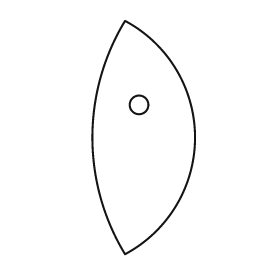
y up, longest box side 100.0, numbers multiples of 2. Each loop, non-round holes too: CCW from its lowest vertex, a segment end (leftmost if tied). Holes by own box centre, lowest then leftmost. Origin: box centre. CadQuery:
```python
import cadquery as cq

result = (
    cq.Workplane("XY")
    .moveTo(-8.0, -50.0)
    .threePointArc((22.0, 0.0), (-8.0, 50.0))
    .threePointArc((-22.0, 0.0), (-8.0, -50.0))
    .close()
    .moveTo(-2.0, 14.0)
    .circle(4.0)
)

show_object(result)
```